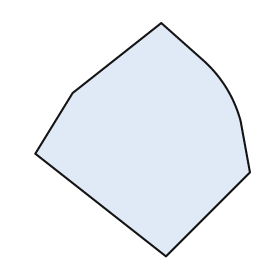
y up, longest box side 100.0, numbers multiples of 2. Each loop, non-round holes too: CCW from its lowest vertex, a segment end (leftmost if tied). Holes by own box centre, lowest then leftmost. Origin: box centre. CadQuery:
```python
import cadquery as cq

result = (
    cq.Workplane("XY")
    .moveTo(10.0, -50.0)
    .lineTo(46.0, -14.0)
    .lineTo(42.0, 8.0)
    .threePointArc((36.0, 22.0), (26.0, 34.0))
    .lineTo(8.0, 50.0)
    .lineTo(-30.0, 20.0)
    .lineTo(-46.0, -6.0)
    .close()
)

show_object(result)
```